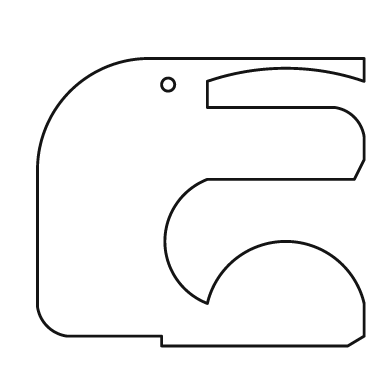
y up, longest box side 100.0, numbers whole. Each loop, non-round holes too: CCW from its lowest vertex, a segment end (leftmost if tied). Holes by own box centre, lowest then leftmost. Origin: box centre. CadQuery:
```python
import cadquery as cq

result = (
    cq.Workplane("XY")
    .moveTo(-12.0, -44.0)
    .lineTo(45.0, -44.0)
    .lineTo(50.0, -41.0)
    .lineTo(50.0, -31.0)
    .threePointArc((26.0, -12.0), (2.0, -31.0))
    .threePointArc((-11.0, -12.0), (2.0, 7.0))
    .lineTo(47.0, 7.0)
    .lineTo(50.0, 13.0)
    .lineTo(50.0, 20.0)
    .threePointArc((47.0, 26.0), (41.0, 29.0))
    .lineTo(2.0, 29.0)
    .lineTo(2.0, 37.0)
    .threePointArc((26.0, 41.0), (50.0, 37.0))
    .lineTo(50.0, 44.0)
    .lineTo(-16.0, 44.0)
    .threePointArc((-40.0, 34.0), (-50.0, 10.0))
    .lineTo(-50.0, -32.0)
    .threePointArc((-47.0, -38.0), (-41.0, -41.0))
    .lineTo(-12.0, -41.0)
    .close()
    .moveTo(-10.0, 36.0)
    .circle(2.0)
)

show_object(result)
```